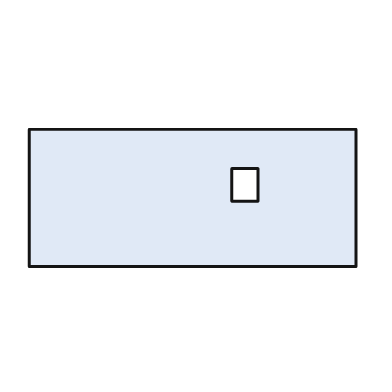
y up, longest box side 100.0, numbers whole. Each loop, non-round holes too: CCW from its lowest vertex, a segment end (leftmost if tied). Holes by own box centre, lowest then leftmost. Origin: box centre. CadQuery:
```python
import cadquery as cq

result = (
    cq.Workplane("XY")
    .moveTo(-50.0, -21.0)
    .lineTo(50.0, -21.0)
    .lineTo(50.0, 21.0)
    .lineTo(-50.0, 21.0)
    .close()
    .moveTo(12.0, -1.0)
    .lineTo(20.0, -1.0)
    .lineTo(20.0, 9.0)
    .lineTo(12.0, 9.0)
    .close()
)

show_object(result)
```